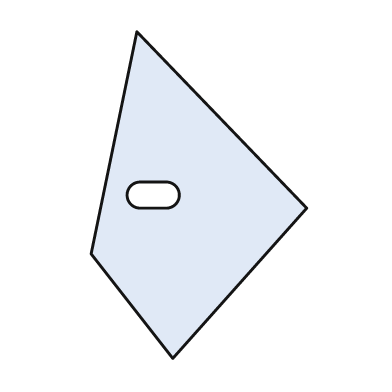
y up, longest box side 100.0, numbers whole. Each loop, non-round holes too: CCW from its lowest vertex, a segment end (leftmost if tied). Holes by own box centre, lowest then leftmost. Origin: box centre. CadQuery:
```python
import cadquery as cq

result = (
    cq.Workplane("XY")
    .moveTo(-8.0, -50.0)
    .lineTo(33.0, -4.0)
    .lineTo(-19.0, 50.0)
    .lineTo(-33.0, -18.0)
    .close()
    .moveTo(-18.0, -4.0)
    .lineTo(-10.0, -4.0)
    .threePointArc((-6.0, 0.0), (-10.0, 4.0))
    .lineTo(-18.0, 4.0)
    .threePointArc((-22.0, 0.0), (-18.0, -4.0))
    .close()
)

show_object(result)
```